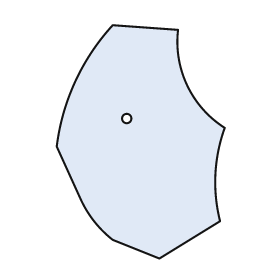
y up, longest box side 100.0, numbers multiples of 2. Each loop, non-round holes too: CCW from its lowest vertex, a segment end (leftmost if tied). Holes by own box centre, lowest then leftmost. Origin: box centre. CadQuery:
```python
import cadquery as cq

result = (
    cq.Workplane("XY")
    .moveTo(8.0, -50.0)
    .lineTo(34.0, -34.0)
    .threePointArc((32.0, -14.0), (36.0, 6.0))
    .threePointArc((20.0, 24.0), (16.0, 48.0))
    .lineTo(-12.0, 50.0)
    .threePointArc((-28.0, 26.0), (-36.0, -2.0))
    .lineTo(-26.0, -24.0)
    .threePointArc((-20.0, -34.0), (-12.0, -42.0))
    .close()
    .moveTo(-6.0, 10.0)
    .circle(2.0)
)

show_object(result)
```